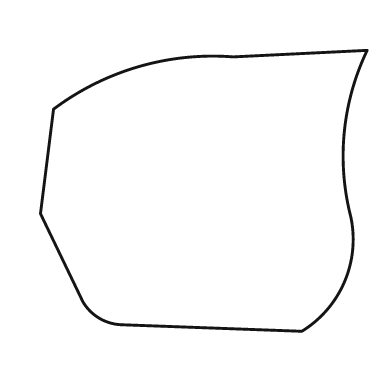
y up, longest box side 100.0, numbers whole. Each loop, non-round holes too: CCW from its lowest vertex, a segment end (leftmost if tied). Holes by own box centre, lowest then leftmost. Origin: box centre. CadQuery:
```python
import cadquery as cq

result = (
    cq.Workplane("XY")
    .moveTo(30.0, -43.0)
    .threePointArc((43.0, -28.0), (45.0, -8.0))
    .threePointArc((43.0, 18.0), (50.0, 43.0))
    .lineTo(9.0, 41.0)
    .threePointArc((-20.0, 38.0), (-46.0, 25.0))
    .lineTo(-50.0, -7.0)
    .lineTo(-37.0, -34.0)
    .threePointArc((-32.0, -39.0), (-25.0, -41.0))
    .close()
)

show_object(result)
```